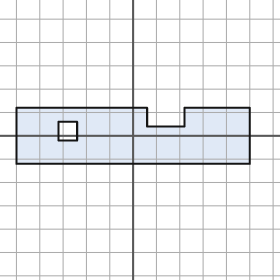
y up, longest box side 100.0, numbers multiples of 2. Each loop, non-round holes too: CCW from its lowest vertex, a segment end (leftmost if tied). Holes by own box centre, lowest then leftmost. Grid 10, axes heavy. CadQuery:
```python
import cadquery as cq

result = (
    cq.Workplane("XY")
    .moveTo(-50.0, -12.0)
    .lineTo(50.0, -12.0)
    .lineTo(50.0, 12.0)
    .lineTo(22.0, 12.0)
    .lineTo(22.0, 4.0)
    .lineTo(6.0, 4.0)
    .lineTo(6.0, 12.0)
    .lineTo(-50.0, 12.0)
    .close()
    .moveTo(-32.0, -2.0)
    .lineTo(-24.0, -2.0)
    .lineTo(-24.0, 6.0)
    .lineTo(-32.0, 6.0)
    .close()
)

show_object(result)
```